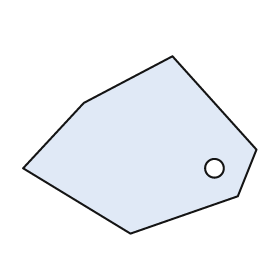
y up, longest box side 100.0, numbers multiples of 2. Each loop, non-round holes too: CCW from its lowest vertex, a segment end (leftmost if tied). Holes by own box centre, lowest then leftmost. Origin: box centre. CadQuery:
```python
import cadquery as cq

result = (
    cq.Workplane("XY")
    .moveTo(-4.0, -38.0)
    .lineTo(42.0, -22.0)
    .lineTo(50.0, -2.0)
    .lineTo(14.0, 38.0)
    .lineTo(-24.0, 18.0)
    .lineTo(-50.0, -10.0)
    .close()
    .moveTo(32.0, -10.0)
    .circle(4.0)
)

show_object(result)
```